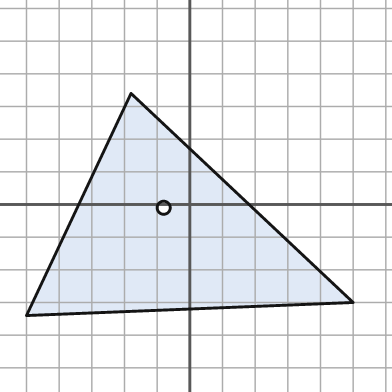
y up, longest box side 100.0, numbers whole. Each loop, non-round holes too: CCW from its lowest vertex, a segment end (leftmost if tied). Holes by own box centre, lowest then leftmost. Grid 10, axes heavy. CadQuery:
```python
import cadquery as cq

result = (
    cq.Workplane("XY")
    .moveTo(-50.0, -34.0)
    .lineTo(50.0, -30.0)
    .lineTo(-18.0, 34.0)
    .close()
    .moveTo(-8.0, -1.0)
    .circle(2.0)
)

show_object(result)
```